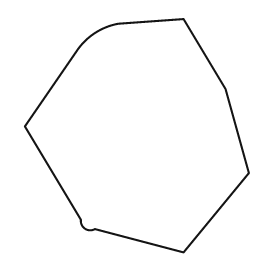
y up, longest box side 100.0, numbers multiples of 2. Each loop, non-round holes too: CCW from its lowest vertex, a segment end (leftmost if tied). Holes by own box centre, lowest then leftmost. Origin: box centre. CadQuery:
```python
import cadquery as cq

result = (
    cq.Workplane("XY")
    .moveTo(20.0, -50.0)
    .lineTo(48.0, -16.0)
    .lineTo(38.0, 20.0)
    .lineTo(20.0, 50.0)
    .lineTo(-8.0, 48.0)
    .threePointArc((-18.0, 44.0), (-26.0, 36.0))
    .lineTo(-48.0, 4.0)
    .lineTo(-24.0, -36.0)
    .threePointArc((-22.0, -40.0), (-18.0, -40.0))
    .close()
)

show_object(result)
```